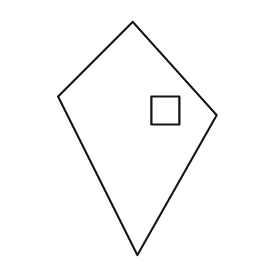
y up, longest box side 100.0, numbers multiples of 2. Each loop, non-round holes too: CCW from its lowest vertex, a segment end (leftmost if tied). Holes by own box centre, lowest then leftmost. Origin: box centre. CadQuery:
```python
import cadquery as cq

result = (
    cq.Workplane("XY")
    .moveTo(0.0, -50.0)
    .lineTo(34.0, 10.0)
    .lineTo(-2.0, 50.0)
    .lineTo(-34.0, 18.0)
    .close()
    .moveTo(6.0, 6.0)
    .lineTo(18.0, 6.0)
    .lineTo(18.0, 18.0)
    .lineTo(6.0, 18.0)
    .close()
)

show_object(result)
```